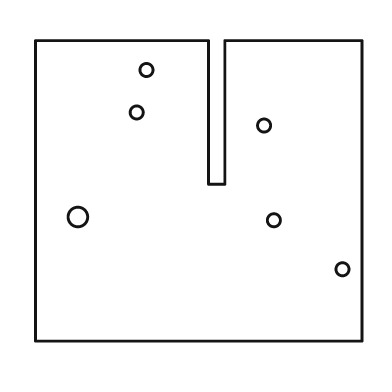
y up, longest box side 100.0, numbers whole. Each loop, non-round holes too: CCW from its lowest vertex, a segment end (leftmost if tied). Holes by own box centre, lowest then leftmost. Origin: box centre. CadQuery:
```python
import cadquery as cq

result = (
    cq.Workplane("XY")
    .moveTo(-50.0, -46.0)
    .lineTo(50.0, -46.0)
    .lineTo(50.0, 46.0)
    .lineTo(8.0, 46.0)
    .lineTo(8.0, 2.0)
    .lineTo(3.0, 2.0)
    .lineTo(3.0, 46.0)
    .lineTo(-50.0, 46.0)
    .close()
    .moveTo(44.0, -24.0)
    .circle(2.0)
    .moveTo(23.0, -9.0)
    .circle(2.0)
    .moveTo(-37.0, -8.0)
    .circle(3.0)
    .moveTo(20.0, 20.0)
    .circle(2.0)
    .moveTo(-19.0, 24.0)
    .circle(2.0)
    .moveTo(-16.0, 37.0)
    .circle(2.0)
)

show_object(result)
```